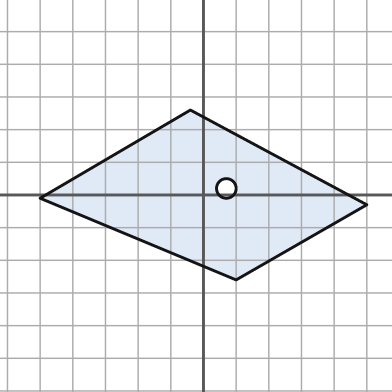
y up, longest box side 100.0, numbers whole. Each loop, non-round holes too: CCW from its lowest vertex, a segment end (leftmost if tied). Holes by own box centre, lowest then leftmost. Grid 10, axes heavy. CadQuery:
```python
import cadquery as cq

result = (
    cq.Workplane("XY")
    .moveTo(10.0, -26.0)
    .lineTo(50.0, -3.0)
    .lineTo(-4.0, 26.0)
    .lineTo(-50.0, -1.0)
    .close()
    .moveTo(7.0, 2.0)
    .circle(3.0)
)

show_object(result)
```